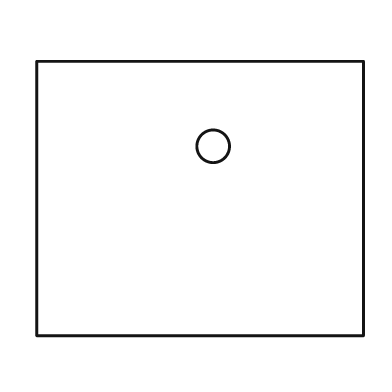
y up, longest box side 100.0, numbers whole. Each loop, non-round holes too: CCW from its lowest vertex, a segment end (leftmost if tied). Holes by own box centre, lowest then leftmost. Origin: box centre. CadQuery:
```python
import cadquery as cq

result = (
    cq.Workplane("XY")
    .moveTo(-50.0, -42.0)
    .lineTo(50.0, -42.0)
    .lineTo(50.0, 42.0)
    .lineTo(-50.0, 42.0)
    .close()
    .moveTo(4.0, 16.0)
    .circle(5.0)
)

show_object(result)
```